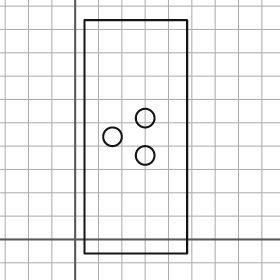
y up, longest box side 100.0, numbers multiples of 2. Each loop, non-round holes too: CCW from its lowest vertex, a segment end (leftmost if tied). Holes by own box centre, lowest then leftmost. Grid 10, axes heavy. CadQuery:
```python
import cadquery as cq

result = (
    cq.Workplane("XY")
    .moveTo(4.0, -6.0)
    .lineTo(48.0, -6.0)
    .lineTo(48.0, 94.0)
    .lineTo(4.0, 94.0)
    .close()
    .moveTo(30.0, 36.0)
    .circle(4.0)
    .moveTo(16.0, 44.0)
    .circle(4.0)
    .moveTo(30.0, 52.0)
    .circle(4.0)
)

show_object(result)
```